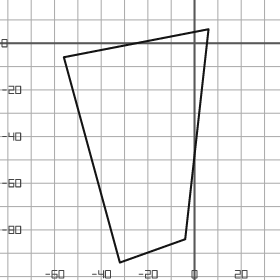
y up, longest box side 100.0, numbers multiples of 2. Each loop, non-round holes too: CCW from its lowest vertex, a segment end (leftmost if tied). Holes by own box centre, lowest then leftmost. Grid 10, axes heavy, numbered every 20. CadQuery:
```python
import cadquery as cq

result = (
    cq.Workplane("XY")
    .moveTo(-32.0, -94.0)
    .lineTo(-4.0, -84.0)
    .lineTo(6.0, 6.0)
    .lineTo(-56.0, -6.0)
    .close()
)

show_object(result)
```